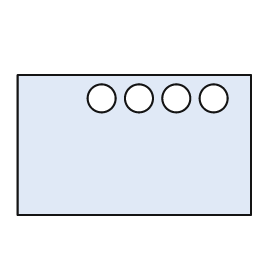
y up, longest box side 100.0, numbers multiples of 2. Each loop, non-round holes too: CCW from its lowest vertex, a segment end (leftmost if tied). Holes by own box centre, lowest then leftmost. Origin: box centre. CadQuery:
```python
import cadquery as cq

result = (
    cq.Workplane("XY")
    .moveTo(-50.0, -30.0)
    .lineTo(50.0, -30.0)
    .lineTo(50.0, 30.0)
    .lineTo(-50.0, 30.0)
    .close()
    .moveTo(-14.0, 20.0)
    .circle(6.0)
    .moveTo(2.0, 20.0)
    .circle(6.0)
    .moveTo(18.0, 20.0)
    .circle(6.0)
    .moveTo(34.0, 20.0)
    .circle(6.0)
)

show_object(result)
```